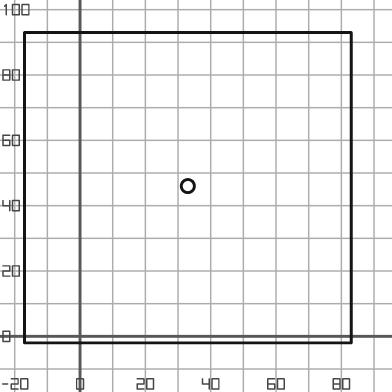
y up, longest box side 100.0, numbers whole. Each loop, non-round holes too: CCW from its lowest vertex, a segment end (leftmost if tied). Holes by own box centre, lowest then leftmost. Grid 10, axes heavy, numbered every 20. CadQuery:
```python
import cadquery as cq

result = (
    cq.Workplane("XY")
    .moveTo(-17.0, -2.0)
    .lineTo(83.0, -2.0)
    .lineTo(83.0, 93.0)
    .lineTo(-17.0, 93.0)
    .close()
    .moveTo(33.0, 46.0)
    .circle(2.0)
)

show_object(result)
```